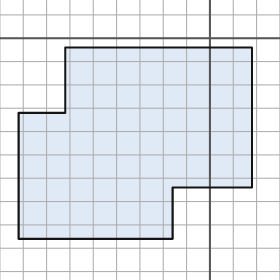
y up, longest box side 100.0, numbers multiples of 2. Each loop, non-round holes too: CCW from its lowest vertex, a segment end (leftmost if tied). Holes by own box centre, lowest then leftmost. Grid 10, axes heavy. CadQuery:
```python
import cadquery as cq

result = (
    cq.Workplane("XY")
    .moveTo(-82.0, -86.0)
    .lineTo(-16.0, -86.0)
    .lineTo(-16.0, -64.0)
    .lineTo(18.0, -64.0)
    .lineTo(18.0, -4.0)
    .lineTo(-62.0, -4.0)
    .lineTo(-62.0, -32.0)
    .lineTo(-82.0, -32.0)
    .close()
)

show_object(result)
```